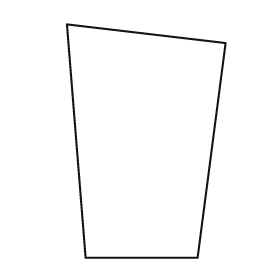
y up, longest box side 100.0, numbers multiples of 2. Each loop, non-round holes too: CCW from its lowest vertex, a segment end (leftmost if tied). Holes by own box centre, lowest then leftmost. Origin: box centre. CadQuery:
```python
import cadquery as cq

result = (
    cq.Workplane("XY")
    .moveTo(-26.0, -50.0)
    .lineTo(22.0, -50.0)
    .lineTo(34.0, 42.0)
    .lineTo(-34.0, 50.0)
    .close()
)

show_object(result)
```